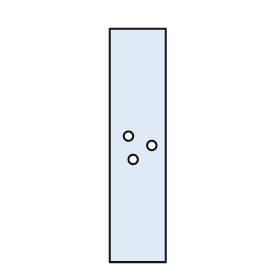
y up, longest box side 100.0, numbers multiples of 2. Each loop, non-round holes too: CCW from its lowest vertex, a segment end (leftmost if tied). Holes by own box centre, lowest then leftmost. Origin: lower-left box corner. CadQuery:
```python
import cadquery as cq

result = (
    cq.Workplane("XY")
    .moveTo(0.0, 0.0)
    .lineTo(24.0, 0.0)
    .lineTo(24.0, 100.0)
    .lineTo(0.0, 100.0)
    .close()
    .moveTo(10.0, 44.0)
    .circle(2.0)
    .moveTo(18.0, 50.0)
    .circle(2.0)
    .moveTo(8.0, 54.0)
    .circle(2.0)
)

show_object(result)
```